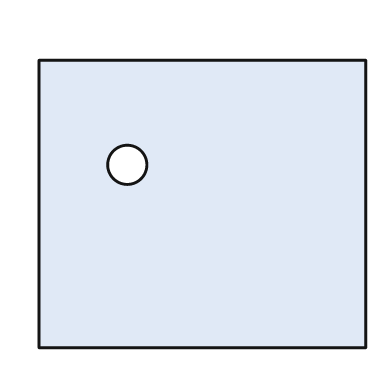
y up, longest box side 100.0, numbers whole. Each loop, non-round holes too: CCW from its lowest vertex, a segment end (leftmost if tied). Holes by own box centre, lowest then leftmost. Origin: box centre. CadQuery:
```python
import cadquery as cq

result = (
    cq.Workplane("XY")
    .moveTo(-50.0, -44.0)
    .lineTo(50.0, -44.0)
    .lineTo(50.0, 44.0)
    .lineTo(-50.0, 44.0)
    .close()
    .moveTo(-23.0, 12.0)
    .circle(6.0)
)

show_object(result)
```